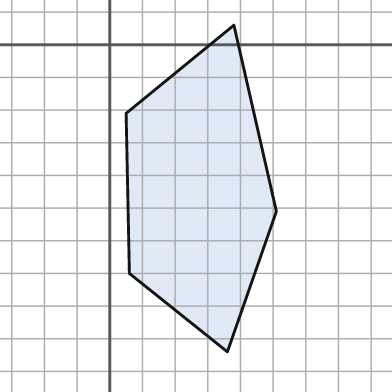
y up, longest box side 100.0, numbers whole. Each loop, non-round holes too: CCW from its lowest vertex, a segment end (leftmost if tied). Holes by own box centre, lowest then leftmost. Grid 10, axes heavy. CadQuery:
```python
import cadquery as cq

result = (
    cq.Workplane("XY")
    .moveTo(36.0, -94.0)
    .lineTo(51.0, -51.0)
    .lineTo(38.0, 6.0)
    .lineTo(5.0, -21.0)
    .lineTo(6.0, -70.0)
    .close()
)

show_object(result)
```